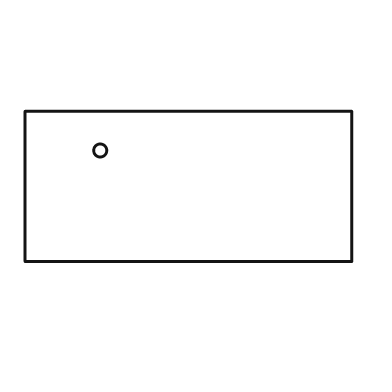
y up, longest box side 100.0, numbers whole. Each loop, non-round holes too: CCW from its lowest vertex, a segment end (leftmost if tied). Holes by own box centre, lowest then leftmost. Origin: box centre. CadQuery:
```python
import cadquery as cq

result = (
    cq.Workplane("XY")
    .moveTo(-50.0, -23.0)
    .lineTo(50.0, -23.0)
    .lineTo(50.0, 23.0)
    .lineTo(-50.0, 23.0)
    .close()
    .moveTo(-27.0, 11.0)
    .circle(2.0)
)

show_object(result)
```